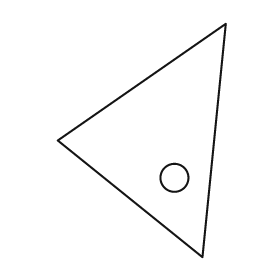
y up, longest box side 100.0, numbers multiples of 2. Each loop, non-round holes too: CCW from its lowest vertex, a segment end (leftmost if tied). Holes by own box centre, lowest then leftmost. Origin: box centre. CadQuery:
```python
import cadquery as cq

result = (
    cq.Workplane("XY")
    .moveTo(26.0, -50.0)
    .lineTo(36.0, 50.0)
    .lineTo(-36.0, 0.0)
    .close()
    .moveTo(14.0, -16.0)
    .circle(6.0)
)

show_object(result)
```